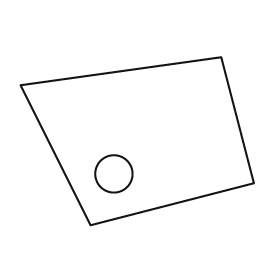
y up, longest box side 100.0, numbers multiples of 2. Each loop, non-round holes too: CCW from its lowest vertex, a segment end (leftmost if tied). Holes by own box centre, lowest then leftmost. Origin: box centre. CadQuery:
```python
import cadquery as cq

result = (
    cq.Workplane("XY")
    .moveTo(-20.0, -36.0)
    .lineTo(50.0, -18.0)
    .lineTo(36.0, 36.0)
    .lineTo(-50.0, 24.0)
    .close()
    .moveTo(-10.0, -14.0)
    .circle(8.0)
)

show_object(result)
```